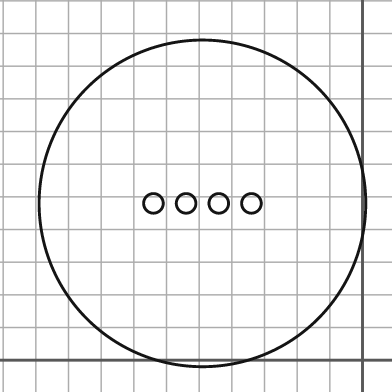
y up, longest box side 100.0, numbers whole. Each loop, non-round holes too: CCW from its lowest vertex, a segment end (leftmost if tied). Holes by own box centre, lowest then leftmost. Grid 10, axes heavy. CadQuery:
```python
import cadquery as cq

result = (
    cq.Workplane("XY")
    .moveTo(-49.0, 48.0)
    .circle(50.0)
    .moveTo(-64.0, 48.0)
    .circle(3.0)
    .moveTo(-54.0, 48.0)
    .circle(3.0)
    .moveTo(-44.0, 48.0)
    .circle(3.0)
    .moveTo(-34.0, 48.0)
    .circle(3.0)
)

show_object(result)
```